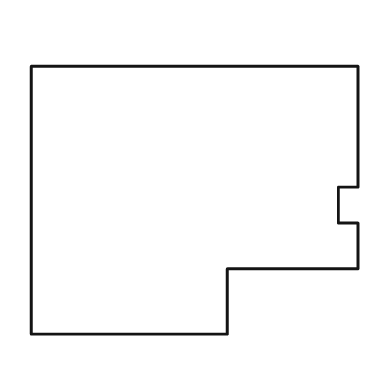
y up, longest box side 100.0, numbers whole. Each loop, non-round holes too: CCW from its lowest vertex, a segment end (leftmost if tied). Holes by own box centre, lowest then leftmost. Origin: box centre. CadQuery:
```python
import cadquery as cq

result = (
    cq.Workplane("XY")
    .moveTo(-50.0, -41.0)
    .lineTo(10.0, -41.0)
    .lineTo(10.0, -21.0)
    .lineTo(50.0, -21.0)
    .lineTo(50.0, -7.0)
    .lineTo(44.0, -7.0)
    .lineTo(44.0, 4.0)
    .lineTo(50.0, 4.0)
    .lineTo(50.0, 41.0)
    .lineTo(-50.0, 41.0)
    .close()
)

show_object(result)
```